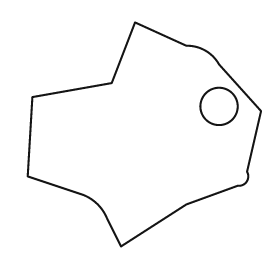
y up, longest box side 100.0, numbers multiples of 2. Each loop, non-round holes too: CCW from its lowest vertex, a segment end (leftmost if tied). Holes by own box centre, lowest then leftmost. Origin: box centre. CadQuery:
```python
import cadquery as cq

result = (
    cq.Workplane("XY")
    .moveTo(-10.0, -48.0)
    .lineTo(18.0, -30.0)
    .lineTo(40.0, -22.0)
    .threePointArc((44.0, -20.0), (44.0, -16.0))
    .lineTo(50.0, 10.0)
    .lineTo(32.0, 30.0)
    .threePointArc((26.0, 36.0), (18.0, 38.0))
    .lineTo(-4.0, 48.0)
    .lineTo(-14.0, 22.0)
    .lineTo(-48.0, 16.0)
    .lineTo(-50.0, -18.0)
    .lineTo(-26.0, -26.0)
    .threePointArc((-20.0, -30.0), (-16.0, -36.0))
    .close()
    .moveTo(32.0, 12.0)
    .circle(8.0)
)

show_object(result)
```